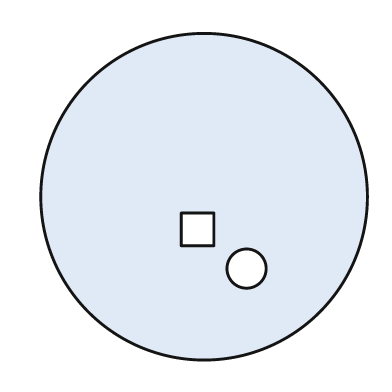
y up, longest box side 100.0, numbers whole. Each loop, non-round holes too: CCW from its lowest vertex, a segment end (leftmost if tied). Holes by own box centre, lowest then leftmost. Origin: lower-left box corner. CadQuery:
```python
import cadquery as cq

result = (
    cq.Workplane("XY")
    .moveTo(50.0, 50.0)
    .circle(50.0)
    .moveTo(63.0, 28.0)
    .circle(6.0)
    .moveTo(43.0, 35.0)
    .lineTo(53.0, 35.0)
    .lineTo(53.0, 45.0)
    .lineTo(43.0, 45.0)
    .close()
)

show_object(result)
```